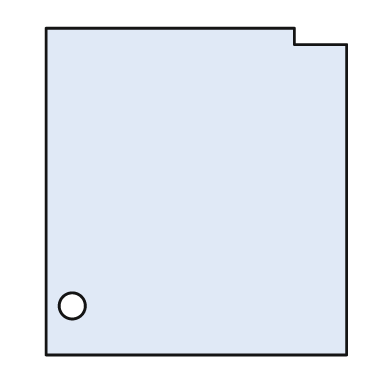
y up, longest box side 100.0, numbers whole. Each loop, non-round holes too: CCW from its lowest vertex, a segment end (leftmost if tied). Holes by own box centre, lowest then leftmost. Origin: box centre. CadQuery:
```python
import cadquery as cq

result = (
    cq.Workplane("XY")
    .moveTo(-46.0, -50.0)
    .lineTo(46.0, -50.0)
    .lineTo(46.0, 45.0)
    .lineTo(30.0, 45.0)
    .lineTo(30.0, 50.0)
    .lineTo(-46.0, 50.0)
    .close()
    .moveTo(-38.0, -35.0)
    .circle(4.0)
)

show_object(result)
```